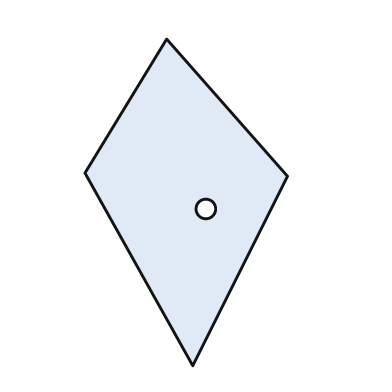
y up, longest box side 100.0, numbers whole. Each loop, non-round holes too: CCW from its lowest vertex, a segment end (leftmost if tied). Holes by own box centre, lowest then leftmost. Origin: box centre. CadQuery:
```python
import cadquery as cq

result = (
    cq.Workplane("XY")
    .moveTo(2.0, -50.0)
    .lineTo(31.0, 8.0)
    .lineTo(-6.0, 50.0)
    .lineTo(-31.0, 9.0)
    .close()
    .moveTo(6.0, -2.0)
    .circle(3.0)
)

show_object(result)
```